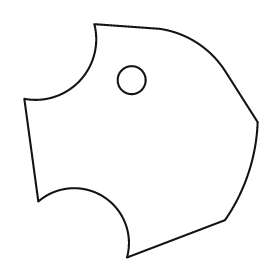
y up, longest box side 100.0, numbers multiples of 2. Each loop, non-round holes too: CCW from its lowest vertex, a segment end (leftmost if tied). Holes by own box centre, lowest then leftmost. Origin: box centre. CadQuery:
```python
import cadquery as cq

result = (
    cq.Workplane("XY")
    .moveTo(-6.0, -50.0)
    .lineTo(36.0, -34.0)
    .threePointArc((46.0, -14.0), (50.0, 8.0))
    .lineTo(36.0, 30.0)
    .threePointArc((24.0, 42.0), (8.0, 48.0))
    .lineTo(-20.0, 50.0)
    .threePointArc((-26.0, 26.0), (-50.0, 18.0))
    .lineTo(-44.0, -26.0)
    .threePointArc((-16.0, -24.0), (-6.0, -50.0))
    .close()
    .moveTo(-4.0, 26.0)
    .circle(6.0)
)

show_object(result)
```